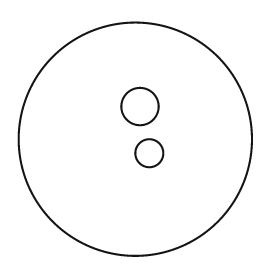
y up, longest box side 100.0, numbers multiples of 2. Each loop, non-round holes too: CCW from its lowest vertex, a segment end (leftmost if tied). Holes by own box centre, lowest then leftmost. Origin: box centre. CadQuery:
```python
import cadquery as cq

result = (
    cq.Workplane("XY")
    .moveTo(0.0, 0.0)
    .circle(50.0)
    .moveTo(6.0, -6.0)
    .circle(6.0)
    .moveTo(2.0, 14.0)
    .circle(8.0)
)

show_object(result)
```